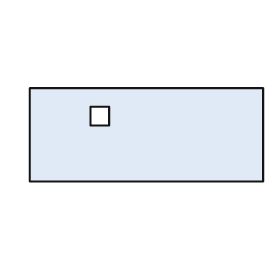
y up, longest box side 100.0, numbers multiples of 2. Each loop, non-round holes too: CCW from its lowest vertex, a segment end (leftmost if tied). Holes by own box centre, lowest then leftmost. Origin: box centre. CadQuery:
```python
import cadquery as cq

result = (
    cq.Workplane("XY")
    .moveTo(-50.0, -20.0)
    .lineTo(50.0, -20.0)
    .lineTo(50.0, 20.0)
    .lineTo(-50.0, 20.0)
    .close()
    .moveTo(-24.0, 4.0)
    .lineTo(-16.0, 4.0)
    .lineTo(-16.0, 12.0)
    .lineTo(-24.0, 12.0)
    .close()
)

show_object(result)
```